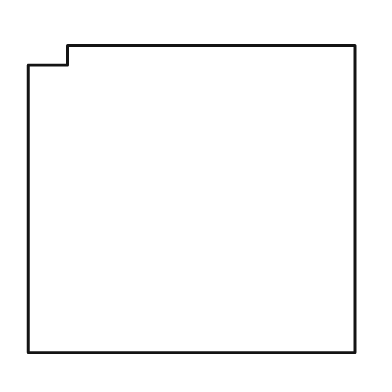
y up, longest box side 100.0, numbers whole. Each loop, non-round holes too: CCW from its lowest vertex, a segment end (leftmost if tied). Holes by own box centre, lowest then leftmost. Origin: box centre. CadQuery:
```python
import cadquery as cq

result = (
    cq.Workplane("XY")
    .moveTo(-50.0, -47.0)
    .lineTo(50.0, -47.0)
    .lineTo(50.0, 47.0)
    .lineTo(-38.0, 47.0)
    .lineTo(-38.0, 41.0)
    .lineTo(-50.0, 41.0)
    .close()
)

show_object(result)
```